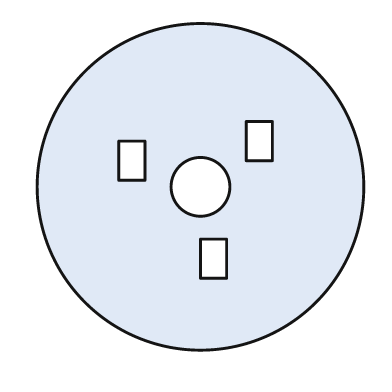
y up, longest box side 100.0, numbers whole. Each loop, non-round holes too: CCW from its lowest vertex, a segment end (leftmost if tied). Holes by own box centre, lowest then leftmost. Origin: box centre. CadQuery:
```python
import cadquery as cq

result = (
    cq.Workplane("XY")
    .moveTo(0.0, 0.0)
    .circle(50.0)
    .moveTo(0.0, -28.0)
    .lineTo(8.0, -28.0)
    .lineTo(8.0, -16.0)
    .lineTo(0.0, -16.0)
    .close()
    .moveTo(0.0, 0.0)
    .circle(9.0)
    .moveTo(-25.0, 2.0)
    .lineTo(-17.0, 2.0)
    .lineTo(-17.0, 14.0)
    .lineTo(-25.0, 14.0)
    .close()
    .moveTo(14.0, 8.0)
    .lineTo(22.0, 8.0)
    .lineTo(22.0, 20.0)
    .lineTo(14.0, 20.0)
    .close()
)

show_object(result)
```